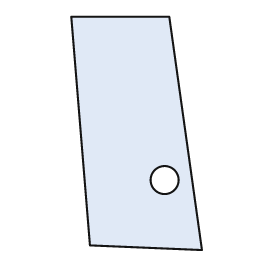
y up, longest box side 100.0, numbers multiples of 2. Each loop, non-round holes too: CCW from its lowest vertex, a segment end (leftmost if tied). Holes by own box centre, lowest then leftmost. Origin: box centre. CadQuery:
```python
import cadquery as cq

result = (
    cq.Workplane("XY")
    .moveTo(28.0, -50.0)
    .lineTo(14.0, 50.0)
    .lineTo(-28.0, 50.0)
    .lineTo(-20.0, -48.0)
    .close()
    .moveTo(12.0, -20.0)
    .circle(6.0)
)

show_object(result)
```